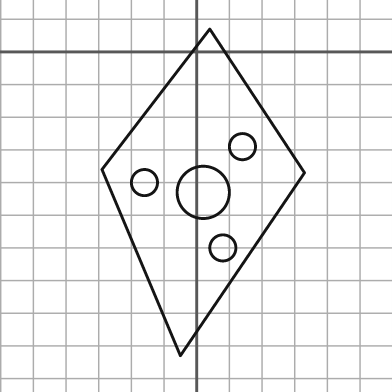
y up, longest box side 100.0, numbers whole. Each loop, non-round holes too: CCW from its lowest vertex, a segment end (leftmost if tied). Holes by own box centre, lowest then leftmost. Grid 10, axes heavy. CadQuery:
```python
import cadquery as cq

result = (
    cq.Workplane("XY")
    .moveTo(-5.0, -93.0)
    .lineTo(33.0, -37.0)
    .lineTo(4.0, 7.0)
    .lineTo(-29.0, -36.0)
    .close()
    .moveTo(8.0, -60.0)
    .circle(4.0)
    .moveTo(2.0, -43.0)
    .circle(8.0)
    .moveTo(-16.0, -40.0)
    .circle(4.0)
    .moveTo(14.0, -29.0)
    .circle(4.0)
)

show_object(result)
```